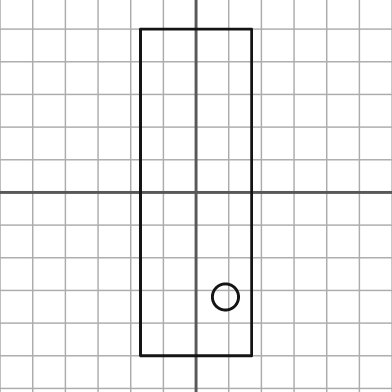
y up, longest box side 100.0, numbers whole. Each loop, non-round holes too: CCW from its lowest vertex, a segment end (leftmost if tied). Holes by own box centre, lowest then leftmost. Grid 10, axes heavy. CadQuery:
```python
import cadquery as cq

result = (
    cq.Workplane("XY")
    .moveTo(-17.0, -50.0)
    .lineTo(17.0, -50.0)
    .lineTo(17.0, 50.0)
    .lineTo(-17.0, 50.0)
    .close()
    .moveTo(9.0, -32.0)
    .circle(4.0)
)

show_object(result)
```